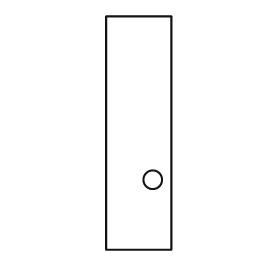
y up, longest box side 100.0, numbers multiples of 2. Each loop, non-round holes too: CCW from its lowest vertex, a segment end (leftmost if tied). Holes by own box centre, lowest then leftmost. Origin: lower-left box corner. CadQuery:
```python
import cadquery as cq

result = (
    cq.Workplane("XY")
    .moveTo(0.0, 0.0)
    .lineTo(28.0, 0.0)
    .lineTo(28.0, 100.0)
    .lineTo(0.0, 100.0)
    .close()
    .moveTo(20.0, 30.0)
    .circle(4.0)
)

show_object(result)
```